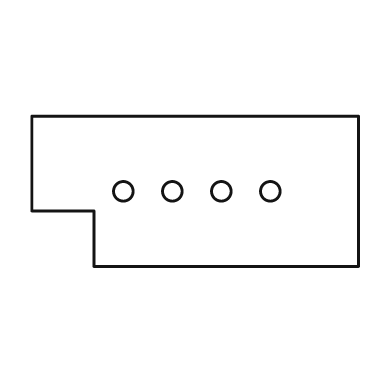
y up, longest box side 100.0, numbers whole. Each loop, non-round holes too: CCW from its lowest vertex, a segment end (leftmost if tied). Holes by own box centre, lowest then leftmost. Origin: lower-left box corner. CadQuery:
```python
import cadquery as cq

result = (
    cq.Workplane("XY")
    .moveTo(19.0, 0.0)
    .lineTo(100.0, 0.0)
    .lineTo(100.0, 46.0)
    .lineTo(0.0, 46.0)
    .lineTo(0.0, 17.0)
    .lineTo(19.0, 17.0)
    .close()
    .moveTo(28.0, 23.0)
    .circle(3.0)
    .moveTo(43.0, 23.0)
    .circle(3.0)
    .moveTo(58.0, 23.0)
    .circle(3.0)
    .moveTo(73.0, 23.0)
    .circle(3.0)
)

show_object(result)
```